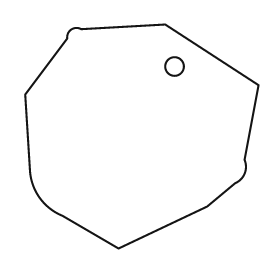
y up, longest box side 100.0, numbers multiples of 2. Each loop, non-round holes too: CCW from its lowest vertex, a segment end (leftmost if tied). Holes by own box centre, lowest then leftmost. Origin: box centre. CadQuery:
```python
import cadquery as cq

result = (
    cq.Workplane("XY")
    .moveTo(-10.0, -48.0)
    .lineTo(28.0, -30.0)
    .lineTo(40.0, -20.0)
    .threePointArc((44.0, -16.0), (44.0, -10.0))
    .lineTo(50.0, 22.0)
    .lineTo(10.0, 48.0)
    .lineTo(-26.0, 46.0)
    .threePointArc((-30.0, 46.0), (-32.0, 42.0))
    .lineTo(-50.0, 18.0)
    .lineTo(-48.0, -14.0)
    .threePointArc((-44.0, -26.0), (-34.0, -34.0))
    .close()
    .moveTo(14.0, 30.0)
    .circle(4.0)
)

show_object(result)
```